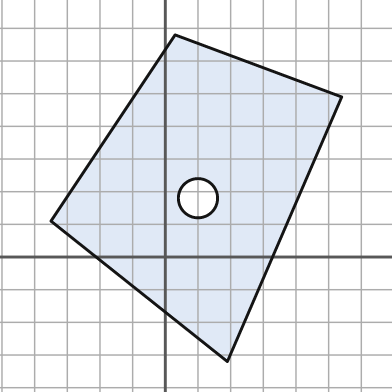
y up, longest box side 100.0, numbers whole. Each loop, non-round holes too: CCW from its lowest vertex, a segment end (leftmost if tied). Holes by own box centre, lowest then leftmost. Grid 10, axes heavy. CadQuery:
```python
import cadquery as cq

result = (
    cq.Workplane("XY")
    .moveTo(19.0, -32.0)
    .lineTo(54.0, 49.0)
    .lineTo(3.0, 68.0)
    .lineTo(-35.0, 11.0)
    .close()
    .moveTo(10.0, 18.0)
    .circle(6.0)
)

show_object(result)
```